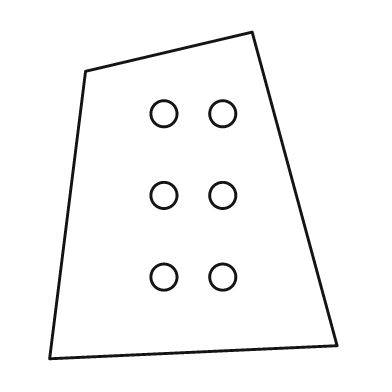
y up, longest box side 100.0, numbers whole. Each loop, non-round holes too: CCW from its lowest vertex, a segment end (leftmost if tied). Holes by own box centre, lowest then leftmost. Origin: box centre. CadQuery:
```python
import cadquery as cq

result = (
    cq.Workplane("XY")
    .moveTo(-44.0, -50.0)
    .lineTo(44.0, -46.0)
    .lineTo(18.0, 50.0)
    .lineTo(-33.0, 38.0)
    .close()
    .moveTo(-9.0, -25.0)
    .circle(4.0)
    .moveTo(9.0, -25.0)
    .circle(4.0)
    .moveTo(-9.0, 0.0)
    .circle(4.0)
    .moveTo(9.0, 0.0)
    .circle(4.0)
    .moveTo(-9.0, 25.0)
    .circle(4.0)
    .moveTo(9.0, 25.0)
    .circle(4.0)
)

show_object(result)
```